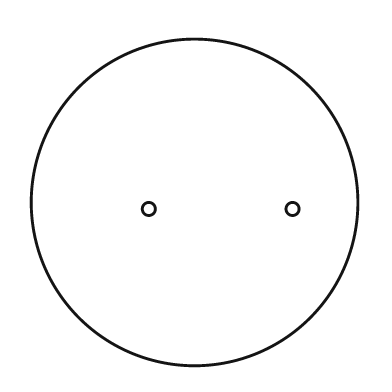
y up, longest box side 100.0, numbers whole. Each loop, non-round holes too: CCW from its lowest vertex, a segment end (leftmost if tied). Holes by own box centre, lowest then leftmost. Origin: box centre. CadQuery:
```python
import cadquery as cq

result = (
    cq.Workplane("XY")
    .moveTo(0.0, 0.0)
    .circle(50.0)
    .moveTo(-14.0, -2.0)
    .circle(2.0)
    .moveTo(30.0, -2.0)
    .circle(2.0)
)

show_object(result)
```